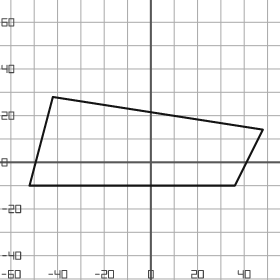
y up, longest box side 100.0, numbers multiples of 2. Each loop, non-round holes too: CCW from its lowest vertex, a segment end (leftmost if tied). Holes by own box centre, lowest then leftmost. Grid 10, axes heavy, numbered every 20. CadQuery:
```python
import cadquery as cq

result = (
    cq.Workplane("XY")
    .moveTo(-52.0, -10.0)
    .lineTo(36.0, -10.0)
    .lineTo(48.0, 14.0)
    .lineTo(-42.0, 28.0)
    .close()
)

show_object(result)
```